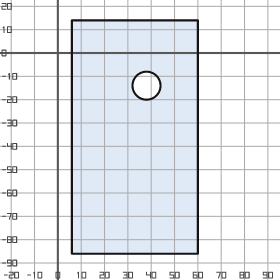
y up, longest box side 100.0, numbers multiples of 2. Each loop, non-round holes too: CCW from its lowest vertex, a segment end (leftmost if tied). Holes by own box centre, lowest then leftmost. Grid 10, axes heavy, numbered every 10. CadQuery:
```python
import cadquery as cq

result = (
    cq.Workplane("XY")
    .moveTo(6.0, -86.0)
    .lineTo(60.0, -86.0)
    .lineTo(60.0, 14.0)
    .lineTo(6.0, 14.0)
    .close()
    .moveTo(38.0, -14.0)
    .circle(6.0)
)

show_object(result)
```